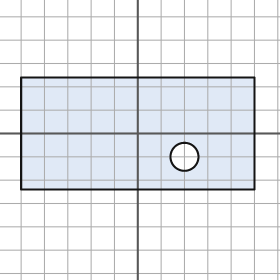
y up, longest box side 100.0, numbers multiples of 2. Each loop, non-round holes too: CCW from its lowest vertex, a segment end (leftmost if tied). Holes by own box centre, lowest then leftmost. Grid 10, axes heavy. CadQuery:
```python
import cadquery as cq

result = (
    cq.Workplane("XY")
    .moveTo(-50.0, -24.0)
    .lineTo(50.0, -24.0)
    .lineTo(50.0, 24.0)
    .lineTo(-50.0, 24.0)
    .close()
    .moveTo(20.0, -10.0)
    .circle(6.0)
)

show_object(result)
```